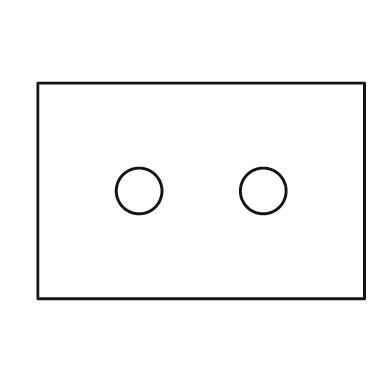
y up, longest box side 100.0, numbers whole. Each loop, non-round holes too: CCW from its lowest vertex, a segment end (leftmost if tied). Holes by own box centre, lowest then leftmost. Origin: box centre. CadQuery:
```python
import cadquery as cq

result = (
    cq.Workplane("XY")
    .moveTo(-50.0, -33.0)
    .lineTo(50.0, -33.0)
    .lineTo(50.0, 33.0)
    .lineTo(-50.0, 33.0)
    .close()
    .moveTo(-19.0, 0.0)
    .circle(7.0)
    .moveTo(19.0, 0.0)
    .circle(7.0)
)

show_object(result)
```